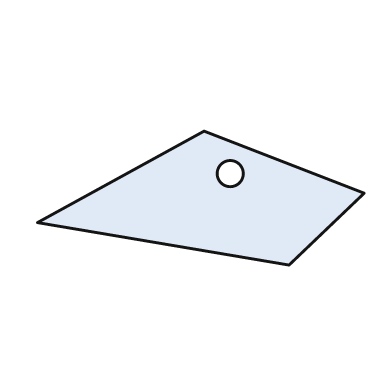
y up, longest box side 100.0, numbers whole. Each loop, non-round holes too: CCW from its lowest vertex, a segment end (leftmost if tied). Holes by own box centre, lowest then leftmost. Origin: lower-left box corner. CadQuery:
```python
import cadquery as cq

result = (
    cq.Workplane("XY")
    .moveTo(77.0, 0.0)
    .lineTo(100.0, 22.0)
    .lineTo(51.0, 41.0)
    .lineTo(0.0, 13.0)
    .close()
    .moveTo(59.0, 28.0)
    .circle(4.0)
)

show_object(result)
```